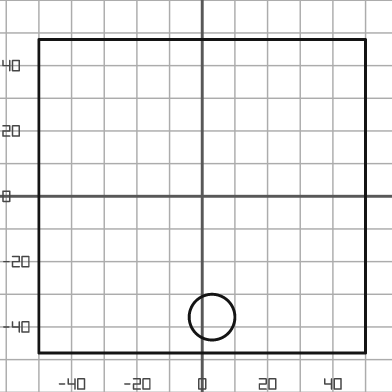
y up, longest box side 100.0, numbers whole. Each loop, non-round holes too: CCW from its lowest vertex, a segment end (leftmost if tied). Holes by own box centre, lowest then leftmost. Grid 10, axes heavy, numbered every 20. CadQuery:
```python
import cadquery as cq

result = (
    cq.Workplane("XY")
    .moveTo(-50.0, -48.0)
    .lineTo(50.0, -48.0)
    .lineTo(50.0, 48.0)
    .lineTo(-50.0, 48.0)
    .close()
    .moveTo(3.0, -37.0)
    .circle(7.0)
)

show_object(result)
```